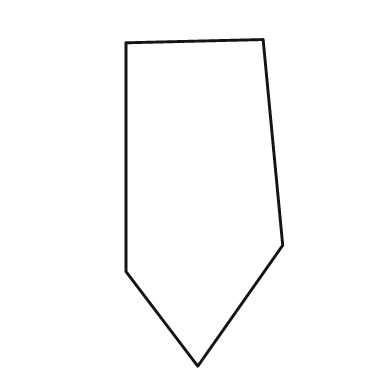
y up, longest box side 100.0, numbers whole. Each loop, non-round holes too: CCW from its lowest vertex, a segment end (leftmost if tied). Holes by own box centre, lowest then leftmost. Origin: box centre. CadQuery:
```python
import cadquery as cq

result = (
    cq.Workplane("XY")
    .moveTo(-2.0, -50.0)
    .lineTo(24.0, -13.0)
    .lineTo(18.0, 50.0)
    .lineTo(-24.0, 49.0)
    .lineTo(-24.0, -21.0)
    .close()
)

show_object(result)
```